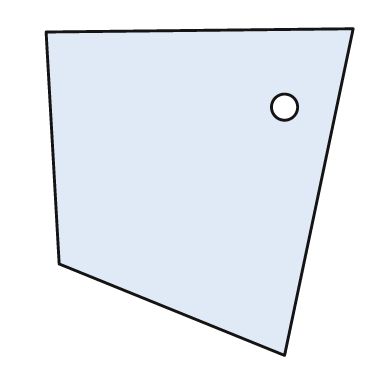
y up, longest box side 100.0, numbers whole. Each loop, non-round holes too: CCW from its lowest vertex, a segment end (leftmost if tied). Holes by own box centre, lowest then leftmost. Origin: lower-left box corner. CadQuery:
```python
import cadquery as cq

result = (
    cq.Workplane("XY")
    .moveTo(73.0, 0.0)
    .lineTo(94.0, 100.0)
    .lineTo(0.0, 99.0)
    .lineTo(4.0, 28.0)
    .close()
    .moveTo(73.0, 76.0)
    .circle(4.0)
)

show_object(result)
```